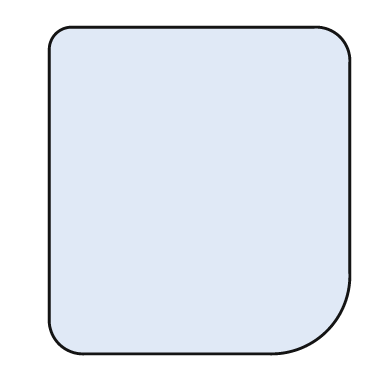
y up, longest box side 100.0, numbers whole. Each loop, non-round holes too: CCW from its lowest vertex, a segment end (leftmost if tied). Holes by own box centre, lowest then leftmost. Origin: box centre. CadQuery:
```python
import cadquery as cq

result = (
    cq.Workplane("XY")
    .moveTo(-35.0, -50.0)
    .lineTo(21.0, -50.0)
    .threePointArc((39.0, -43.0), (46.0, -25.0))
    .lineTo(46.0, 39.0)
    .threePointArc((43.0, 47.0), (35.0, 50.0))
    .lineTo(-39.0, 50.0)
    .threePointArc((-44.0, 48.0), (-46.0, 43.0))
    .lineTo(-46.0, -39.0)
    .threePointArc((-43.0, -47.0), (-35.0, -50.0))
    .close()
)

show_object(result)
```